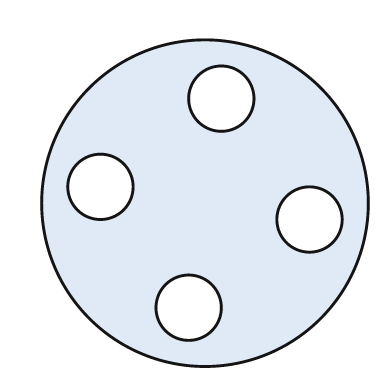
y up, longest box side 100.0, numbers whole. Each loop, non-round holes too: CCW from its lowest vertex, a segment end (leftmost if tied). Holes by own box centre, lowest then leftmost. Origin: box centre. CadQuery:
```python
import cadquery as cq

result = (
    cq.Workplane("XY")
    .moveTo(0.0, 0.0)
    .circle(50.0)
    .moveTo(-5.0, -32.0)
    .circle(10.0)
    .moveTo(32.0, -5.0)
    .circle(10.0)
    .moveTo(-32.0, 5.0)
    .circle(10.0)
    .moveTo(5.0, 32.0)
    .circle(10.0)
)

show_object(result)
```